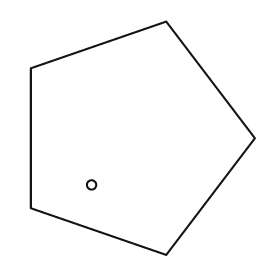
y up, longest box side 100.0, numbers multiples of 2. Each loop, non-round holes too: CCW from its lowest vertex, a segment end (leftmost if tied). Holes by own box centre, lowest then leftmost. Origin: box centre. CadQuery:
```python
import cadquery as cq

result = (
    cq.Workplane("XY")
    .moveTo(10.0, -50.0)
    .lineTo(48.0, 0.0)
    .lineTo(10.0, 50.0)
    .lineTo(-48.0, 30.0)
    .lineTo(-48.0, -30.0)
    .close()
    .moveTo(-22.0, -20.0)
    .circle(2.0)
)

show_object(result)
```